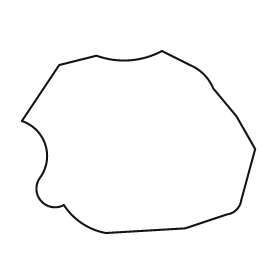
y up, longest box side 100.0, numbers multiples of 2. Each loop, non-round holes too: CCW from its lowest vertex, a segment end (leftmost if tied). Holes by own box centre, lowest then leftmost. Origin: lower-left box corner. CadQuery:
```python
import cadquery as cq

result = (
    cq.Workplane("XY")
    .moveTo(36.0, 0.0)
    .lineTo(70.0, 2.0)
    .lineTo(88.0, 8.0)
    .threePointArc((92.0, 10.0), (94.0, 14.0))
    .lineTo(100.0, 36.0)
    .lineTo(92.0, 50.0)
    .lineTo(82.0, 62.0)
    .threePointArc((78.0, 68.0), (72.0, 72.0))
    .lineTo(60.0, 78.0)
    .threePointArc((46.0, 74.0), (32.0, 76.0))
    .lineTo(16.0, 72.0)
    .lineTo(0.0, 48.0)
    .threePointArc((10.0, 38.0), (8.0, 24.0))
    .threePointArc((8.0, 14.0), (18.0, 12.0))
    .threePointArc((26.0, 4.0), (36.0, 0.0))
    .close()
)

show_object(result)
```